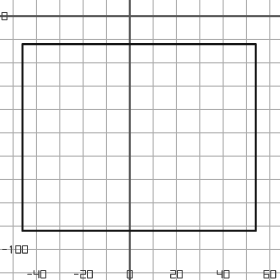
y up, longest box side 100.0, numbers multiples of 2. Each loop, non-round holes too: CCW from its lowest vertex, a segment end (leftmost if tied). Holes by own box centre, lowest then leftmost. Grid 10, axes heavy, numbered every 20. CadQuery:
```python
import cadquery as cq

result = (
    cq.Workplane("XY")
    .moveTo(-46.0, -92.0)
    .lineTo(54.0, -92.0)
    .lineTo(54.0, -12.0)
    .lineTo(-46.0, -12.0)
    .close()
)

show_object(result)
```